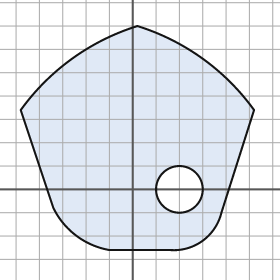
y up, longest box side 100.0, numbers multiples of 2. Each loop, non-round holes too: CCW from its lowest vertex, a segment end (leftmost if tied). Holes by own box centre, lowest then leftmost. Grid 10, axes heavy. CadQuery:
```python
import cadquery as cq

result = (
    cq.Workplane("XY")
    .moveTo(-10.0, -26.0)
    .lineTo(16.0, -26.0)
    .threePointArc((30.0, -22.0), (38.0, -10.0))
    .lineTo(52.0, 34.0)
    .threePointArc((30.0, 56.0), (2.0, 70.0))
    .threePointArc((-26.0, 56.0), (-48.0, 34.0))
    .lineTo(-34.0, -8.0)
    .threePointArc((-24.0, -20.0), (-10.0, -26.0))
    .close()
    .moveTo(20.0, 0.0)
    .circle(10.0)
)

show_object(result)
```